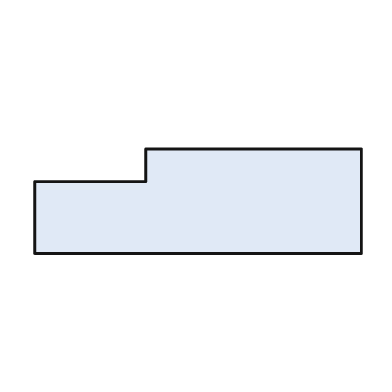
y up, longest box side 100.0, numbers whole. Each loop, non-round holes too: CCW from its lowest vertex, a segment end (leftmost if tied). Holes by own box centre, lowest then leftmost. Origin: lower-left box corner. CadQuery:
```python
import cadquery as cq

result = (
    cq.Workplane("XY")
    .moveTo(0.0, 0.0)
    .lineTo(100.0, 0.0)
    .lineTo(100.0, 32.0)
    .lineTo(34.0, 32.0)
    .lineTo(34.0, 22.0)
    .lineTo(0.0, 22.0)
    .close()
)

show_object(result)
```